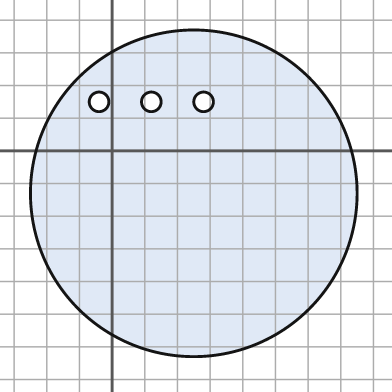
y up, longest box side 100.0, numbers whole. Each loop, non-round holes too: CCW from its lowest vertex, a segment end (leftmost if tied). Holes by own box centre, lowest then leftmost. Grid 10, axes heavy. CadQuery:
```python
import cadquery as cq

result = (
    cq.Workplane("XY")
    .moveTo(25.0, -13.0)
    .circle(50.0)
    .moveTo(-4.0, 15.0)
    .circle(3.0)
    .moveTo(12.0, 15.0)
    .circle(3.0)
    .moveTo(28.0, 15.0)
    .circle(3.0)
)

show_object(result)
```